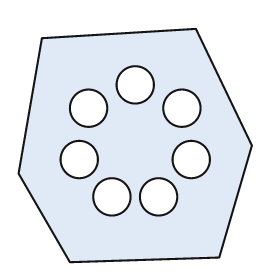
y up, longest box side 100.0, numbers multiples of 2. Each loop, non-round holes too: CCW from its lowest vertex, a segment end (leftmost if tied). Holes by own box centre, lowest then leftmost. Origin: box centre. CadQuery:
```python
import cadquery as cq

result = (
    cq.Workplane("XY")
    .moveTo(-28.0, -50.0)
    .lineTo(36.0, -48.0)
    .lineTo(50.0, 0.0)
    .lineTo(26.0, 50.0)
    .lineTo(-40.0, 46.0)
    .lineTo(-50.0, -12.0)
    .close()
    .moveTo(-10.0, -22.0)
    .circle(8.0)
    .moveTo(10.0, -22.0)
    .circle(8.0)
    .moveTo(-24.0, -6.0)
    .circle(8.0)
    .moveTo(24.0, -6.0)
    .circle(8.0)
    .moveTo(-20.0, 16.0)
    .circle(8.0)
    .moveTo(20.0, 16.0)
    .circle(8.0)
    .moveTo(0.0, 26.0)
    .circle(8.0)
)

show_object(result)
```